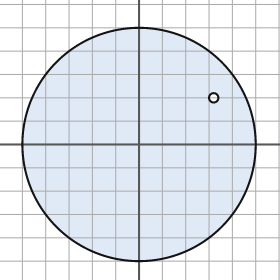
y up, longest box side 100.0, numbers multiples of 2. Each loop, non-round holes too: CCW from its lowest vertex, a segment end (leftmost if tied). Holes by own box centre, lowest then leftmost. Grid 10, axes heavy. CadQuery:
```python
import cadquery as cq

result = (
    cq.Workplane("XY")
    .moveTo(0.0, 0.0)
    .circle(50.0)
    .moveTo(32.0, 20.0)
    .circle(2.0)
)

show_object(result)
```